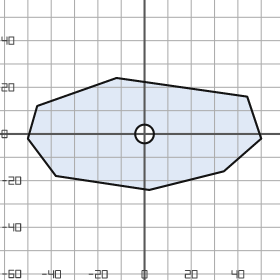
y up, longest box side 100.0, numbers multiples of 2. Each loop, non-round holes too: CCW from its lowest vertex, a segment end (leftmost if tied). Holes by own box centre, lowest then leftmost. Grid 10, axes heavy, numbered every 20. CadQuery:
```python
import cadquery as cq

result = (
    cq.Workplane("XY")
    .moveTo(2.0, -24.0)
    .lineTo(34.0, -16.0)
    .lineTo(50.0, -2.0)
    .lineTo(44.0, 16.0)
    .lineTo(-12.0, 24.0)
    .lineTo(-46.0, 12.0)
    .lineTo(-50.0, -2.0)
    .lineTo(-38.0, -18.0)
    .close()
    .moveTo(0.0, 0.0)
    .circle(4.0)
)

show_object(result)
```